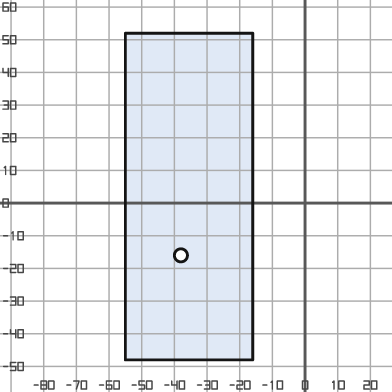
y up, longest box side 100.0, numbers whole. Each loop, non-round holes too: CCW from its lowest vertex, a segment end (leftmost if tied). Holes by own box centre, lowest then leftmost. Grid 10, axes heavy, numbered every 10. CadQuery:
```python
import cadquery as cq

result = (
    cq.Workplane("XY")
    .moveTo(-55.0, -48.0)
    .lineTo(-16.0, -48.0)
    .lineTo(-16.0, 52.0)
    .lineTo(-55.0, 52.0)
    .close()
    .moveTo(-38.0, -16.0)
    .circle(2.0)
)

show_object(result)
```